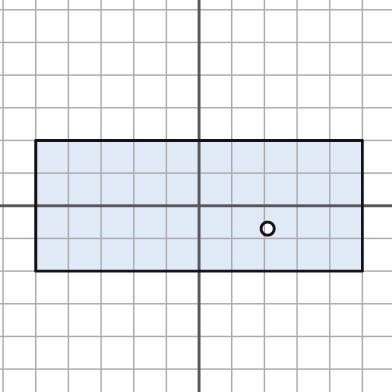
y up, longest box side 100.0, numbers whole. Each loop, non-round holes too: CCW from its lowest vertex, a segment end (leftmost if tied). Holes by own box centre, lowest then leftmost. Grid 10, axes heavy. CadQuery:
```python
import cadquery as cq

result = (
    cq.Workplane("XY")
    .moveTo(-50.0, -20.0)
    .lineTo(50.0, -20.0)
    .lineTo(50.0, 20.0)
    .lineTo(-50.0, 20.0)
    .close()
    .moveTo(21.0, -7.0)
    .circle(2.0)
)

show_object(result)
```